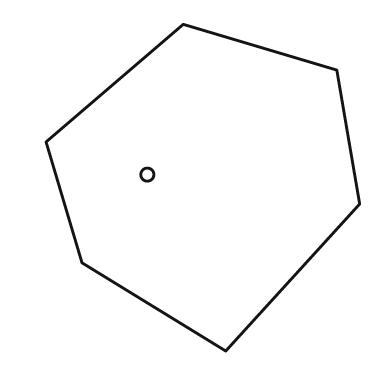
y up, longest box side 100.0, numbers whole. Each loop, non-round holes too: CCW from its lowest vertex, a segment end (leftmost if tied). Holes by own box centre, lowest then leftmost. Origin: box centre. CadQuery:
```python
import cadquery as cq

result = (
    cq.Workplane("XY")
    .moveTo(7.0, -50.0)
    .lineTo(48.0, -5.0)
    .lineTo(41.0, 36.0)
    .lineTo(-6.0, 50.0)
    .lineTo(-48.0, 14.0)
    .lineTo(-37.0, -23.0)
    .close()
    .moveTo(-17.0, 4.0)
    .circle(2.0)
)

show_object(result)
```